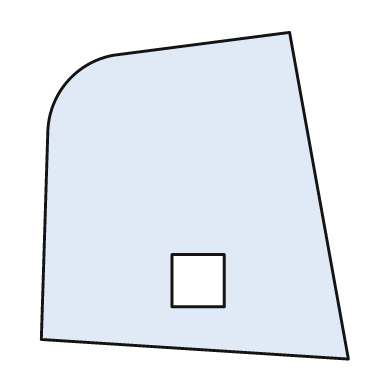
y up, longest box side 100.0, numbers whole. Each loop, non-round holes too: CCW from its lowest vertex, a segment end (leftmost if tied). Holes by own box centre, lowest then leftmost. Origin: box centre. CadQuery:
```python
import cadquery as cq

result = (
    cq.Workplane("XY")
    .moveTo(47.0, -50.0)
    .lineTo(29.0, 50.0)
    .lineTo(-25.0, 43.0)
    .threePointArc((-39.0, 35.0), (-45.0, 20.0))
    .lineTo(-47.0, -44.0)
    .close()
    .moveTo(-7.0, -34.0)
    .lineTo(9.0, -34.0)
    .lineTo(9.0, -18.0)
    .lineTo(-7.0, -18.0)
    .close()
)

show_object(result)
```